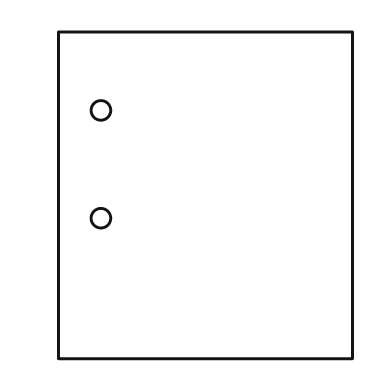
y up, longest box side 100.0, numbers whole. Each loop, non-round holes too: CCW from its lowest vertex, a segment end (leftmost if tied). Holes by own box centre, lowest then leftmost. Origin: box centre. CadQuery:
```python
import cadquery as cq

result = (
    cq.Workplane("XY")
    .moveTo(-45.0, -50.0)
    .lineTo(45.0, -50.0)
    .lineTo(45.0, 50.0)
    .lineTo(-45.0, 50.0)
    .close()
    .moveTo(-32.0, -7.0)
    .circle(3.0)
    .moveTo(-32.0, 26.0)
    .circle(3.0)
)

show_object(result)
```